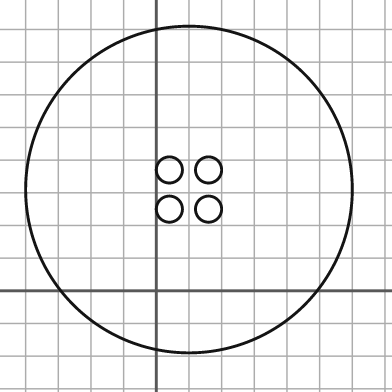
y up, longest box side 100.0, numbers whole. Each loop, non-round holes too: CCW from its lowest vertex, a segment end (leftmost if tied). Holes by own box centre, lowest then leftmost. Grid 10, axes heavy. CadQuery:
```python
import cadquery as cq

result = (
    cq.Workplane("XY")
    .moveTo(10.0, 31.0)
    .circle(50.0)
    .moveTo(4.0, 25.0)
    .circle(4.0)
    .moveTo(16.0, 25.0)
    .circle(4.0)
    .moveTo(4.0, 37.0)
    .circle(4.0)
    .moveTo(16.0, 37.0)
    .circle(4.0)
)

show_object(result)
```